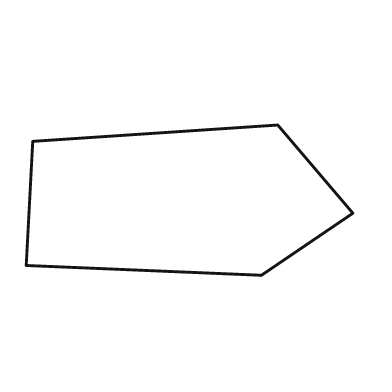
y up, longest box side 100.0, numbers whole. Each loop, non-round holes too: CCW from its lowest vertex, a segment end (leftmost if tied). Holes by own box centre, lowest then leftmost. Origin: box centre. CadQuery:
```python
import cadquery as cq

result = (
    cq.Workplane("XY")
    .moveTo(22.0, -23.0)
    .lineTo(50.0, -4.0)
    .lineTo(27.0, 23.0)
    .lineTo(-48.0, 18.0)
    .lineTo(-50.0, -20.0)
    .close()
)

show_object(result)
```